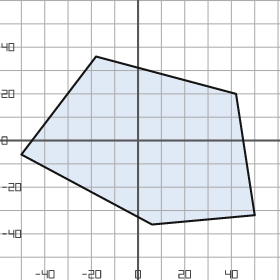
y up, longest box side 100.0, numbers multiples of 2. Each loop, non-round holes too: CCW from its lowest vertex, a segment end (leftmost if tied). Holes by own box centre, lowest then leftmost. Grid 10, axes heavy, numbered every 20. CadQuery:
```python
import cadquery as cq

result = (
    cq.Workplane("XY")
    .moveTo(6.0, -36.0)
    .lineTo(50.0, -32.0)
    .lineTo(42.0, 20.0)
    .lineTo(-18.0, 36.0)
    .lineTo(-50.0, -6.0)
    .close()
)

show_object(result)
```